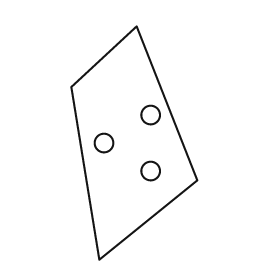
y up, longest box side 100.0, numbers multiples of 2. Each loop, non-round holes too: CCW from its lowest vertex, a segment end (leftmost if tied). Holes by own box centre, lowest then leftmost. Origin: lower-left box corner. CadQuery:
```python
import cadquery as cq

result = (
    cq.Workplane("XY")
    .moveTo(12.0, 0.0)
    .lineTo(54.0, 34.0)
    .lineTo(28.0, 100.0)
    .lineTo(0.0, 74.0)
    .close()
    .moveTo(34.0, 38.0)
    .circle(4.0)
    .moveTo(14.0, 50.0)
    .circle(4.0)
    .moveTo(34.0, 62.0)
    .circle(4.0)
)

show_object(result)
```